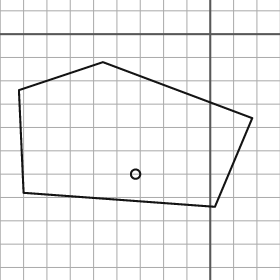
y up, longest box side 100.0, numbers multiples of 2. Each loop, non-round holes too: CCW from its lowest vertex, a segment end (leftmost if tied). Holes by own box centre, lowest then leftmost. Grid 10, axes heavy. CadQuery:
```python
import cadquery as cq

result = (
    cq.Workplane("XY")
    .moveTo(2.0, -74.0)
    .lineTo(18.0, -36.0)
    .lineTo(-46.0, -12.0)
    .lineTo(-82.0, -24.0)
    .lineTo(-80.0, -68.0)
    .close()
    .moveTo(-32.0, -60.0)
    .circle(2.0)
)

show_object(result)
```